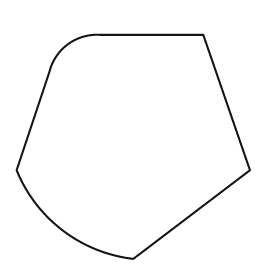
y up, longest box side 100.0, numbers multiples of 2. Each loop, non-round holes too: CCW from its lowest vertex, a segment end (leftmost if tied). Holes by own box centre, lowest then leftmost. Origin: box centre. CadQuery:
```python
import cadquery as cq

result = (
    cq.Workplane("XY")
    .moveTo(0.0, -48.0)
    .lineTo(50.0, -10.0)
    .lineTo(30.0, 48.0)
    .lineTo(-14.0, 48.0)
    .threePointArc((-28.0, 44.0), (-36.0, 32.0))
    .lineTo(-50.0, -10.0)
    .threePointArc((-30.0, -36.0), (0.0, -48.0))
    .close()
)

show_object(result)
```